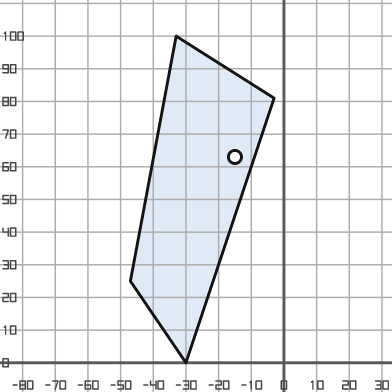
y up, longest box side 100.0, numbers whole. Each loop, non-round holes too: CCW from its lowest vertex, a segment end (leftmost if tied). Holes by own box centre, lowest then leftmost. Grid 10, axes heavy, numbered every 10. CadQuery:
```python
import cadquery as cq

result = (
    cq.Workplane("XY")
    .moveTo(-30.0, 0.0)
    .lineTo(-3.0, 81.0)
    .lineTo(-33.0, 100.0)
    .lineTo(-47.0, 25.0)
    .close()
    .moveTo(-15.0, 63.0)
    .circle(2.0)
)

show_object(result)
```